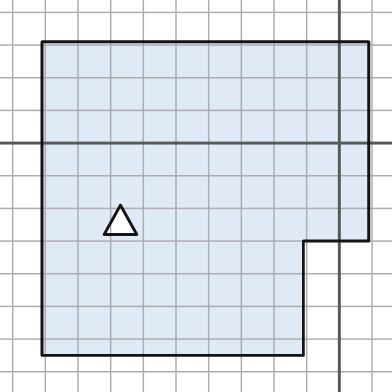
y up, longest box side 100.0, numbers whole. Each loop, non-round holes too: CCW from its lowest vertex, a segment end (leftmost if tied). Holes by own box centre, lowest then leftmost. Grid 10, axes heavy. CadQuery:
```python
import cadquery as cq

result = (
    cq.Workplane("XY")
    .moveTo(-91.0, -65.0)
    .lineTo(-11.0, -65.0)
    .lineTo(-11.0, -30.0)
    .lineTo(9.0, -30.0)
    .lineTo(9.0, 31.0)
    .lineTo(-91.0, 31.0)
    .close()
    .moveTo(-72.0, -28.0)
    .lineTo(-62.0, -28.0)
    .lineTo(-67.0, -19.0)
    .close()
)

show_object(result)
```